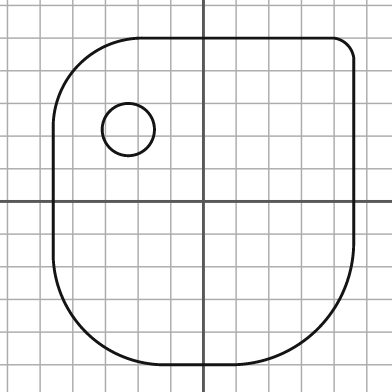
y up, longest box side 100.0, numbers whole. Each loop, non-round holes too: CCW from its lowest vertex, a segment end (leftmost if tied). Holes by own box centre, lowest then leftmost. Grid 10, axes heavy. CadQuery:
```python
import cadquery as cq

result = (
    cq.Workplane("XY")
    .moveTo(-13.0, -50.0)
    .lineTo(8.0, -50.0)
    .threePointArc((35.0, -39.0), (46.0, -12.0))
    .lineTo(46.0, 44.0)
    .threePointArc((44.0, 48.0), (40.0, 50.0))
    .lineTo(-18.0, 50.0)
    .threePointArc((-38.0, 42.0), (-46.0, 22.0))
    .lineTo(-46.0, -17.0)
    .threePointArc((-36.0, -40.0), (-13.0, -50.0))
    .close()
    .moveTo(-23.0, 22.0)
    .circle(8.0)
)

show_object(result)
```